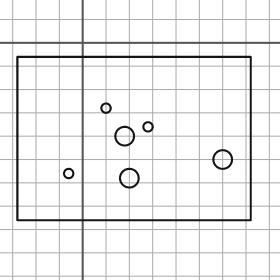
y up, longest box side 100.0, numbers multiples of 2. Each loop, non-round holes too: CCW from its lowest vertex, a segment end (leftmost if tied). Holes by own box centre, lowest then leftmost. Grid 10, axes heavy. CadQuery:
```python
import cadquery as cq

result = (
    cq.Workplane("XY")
    .moveTo(-28.0, -76.0)
    .lineTo(72.0, -76.0)
    .lineTo(72.0, -6.0)
    .lineTo(-28.0, -6.0)
    .close()
    .moveTo(20.0, -58.0)
    .circle(4.0)
    .moveTo(-6.0, -56.0)
    .circle(2.0)
    .moveTo(60.0, -50.0)
    .circle(4.0)
    .moveTo(18.0, -40.0)
    .circle(4.0)
    .moveTo(28.0, -36.0)
    .circle(2.0)
    .moveTo(10.0, -28.0)
    .circle(2.0)
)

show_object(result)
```